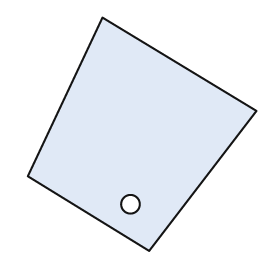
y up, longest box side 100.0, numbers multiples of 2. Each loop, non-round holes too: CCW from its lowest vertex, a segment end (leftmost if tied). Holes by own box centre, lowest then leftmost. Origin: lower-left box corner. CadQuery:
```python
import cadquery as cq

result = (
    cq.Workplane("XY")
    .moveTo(52.0, 0.0)
    .lineTo(98.0, 60.0)
    .lineTo(32.0, 100.0)
    .lineTo(0.0, 32.0)
    .close()
    .moveTo(44.0, 20.0)
    .circle(4.0)
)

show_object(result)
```